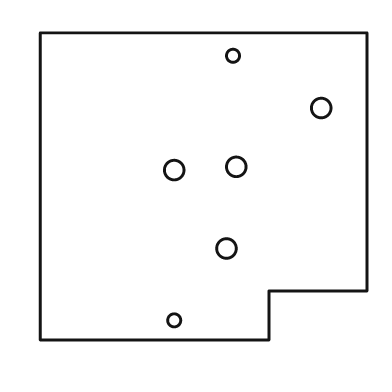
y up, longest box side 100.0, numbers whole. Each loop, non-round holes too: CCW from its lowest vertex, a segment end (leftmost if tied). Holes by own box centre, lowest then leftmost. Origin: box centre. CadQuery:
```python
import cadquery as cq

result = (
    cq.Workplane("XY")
    .moveTo(-50.0, -47.0)
    .lineTo(20.0, -47.0)
    .lineTo(20.0, -32.0)
    .lineTo(50.0, -32.0)
    .lineTo(50.0, 47.0)
    .lineTo(-50.0, 47.0)
    .close()
    .moveTo(-9.0, -41.0)
    .circle(2.0)
    .moveTo(7.0, -19.0)
    .circle(3.0)
    .moveTo(-9.0, 5.0)
    .circle(3.0)
    .moveTo(10.0, 6.0)
    .circle(3.0)
    .moveTo(36.0, 24.0)
    .circle(3.0)
    .moveTo(9.0, 40.0)
    .circle(2.0)
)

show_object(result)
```